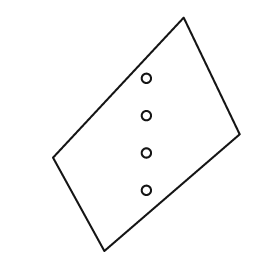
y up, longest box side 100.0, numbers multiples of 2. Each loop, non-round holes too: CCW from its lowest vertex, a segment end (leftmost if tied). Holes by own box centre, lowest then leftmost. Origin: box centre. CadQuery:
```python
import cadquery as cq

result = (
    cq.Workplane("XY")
    .moveTo(-18.0, -50.0)
    .lineTo(40.0, 0.0)
    .lineTo(16.0, 50.0)
    .lineTo(-40.0, -10.0)
    .close()
    .moveTo(0.0, -24.0)
    .circle(2.0)
    .moveTo(0.0, -8.0)
    .circle(2.0)
    .moveTo(0.0, 8.0)
    .circle(2.0)
    .moveTo(0.0, 24.0)
    .circle(2.0)
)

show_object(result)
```